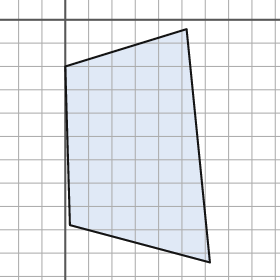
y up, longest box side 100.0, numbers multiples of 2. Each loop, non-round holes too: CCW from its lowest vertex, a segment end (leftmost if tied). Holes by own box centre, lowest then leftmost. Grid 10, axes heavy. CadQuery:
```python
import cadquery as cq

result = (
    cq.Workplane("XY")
    .moveTo(62.0, -104.0)
    .lineTo(52.0, -4.0)
    .lineTo(0.0, -20.0)
    .lineTo(2.0, -88.0)
    .close()
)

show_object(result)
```